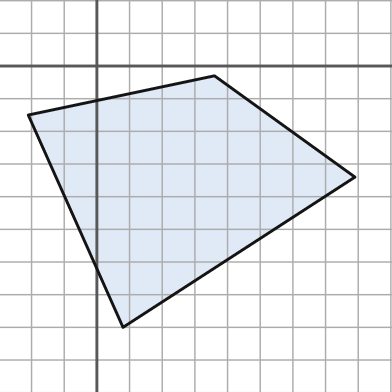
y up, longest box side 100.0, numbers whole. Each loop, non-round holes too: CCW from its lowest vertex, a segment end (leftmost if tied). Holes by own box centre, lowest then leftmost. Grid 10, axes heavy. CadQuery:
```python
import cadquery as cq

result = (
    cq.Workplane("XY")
    .moveTo(8.0, -80.0)
    .lineTo(79.0, -34.0)
    .lineTo(36.0, -3.0)
    .lineTo(-21.0, -15.0)
    .close()
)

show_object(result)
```